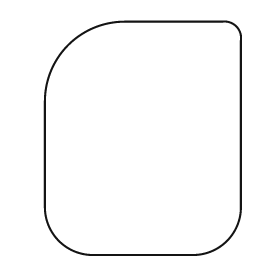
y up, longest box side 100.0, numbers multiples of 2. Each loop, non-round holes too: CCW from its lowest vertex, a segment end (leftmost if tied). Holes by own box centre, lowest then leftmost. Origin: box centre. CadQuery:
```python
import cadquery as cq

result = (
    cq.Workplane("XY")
    .moveTo(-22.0, -50.0)
    .lineTo(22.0, -50.0)
    .threePointArc((36.0, -44.0), (42.0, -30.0))
    .lineTo(42.0, 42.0)
    .threePointArc((40.0, 48.0), (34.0, 50.0))
    .lineTo(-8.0, 50.0)
    .threePointArc((-32.0, 40.0), (-42.0, 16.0))
    .lineTo(-42.0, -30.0)
    .threePointArc((-36.0, -44.0), (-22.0, -50.0))
    .close()
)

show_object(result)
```